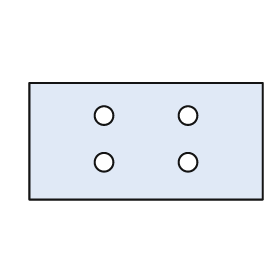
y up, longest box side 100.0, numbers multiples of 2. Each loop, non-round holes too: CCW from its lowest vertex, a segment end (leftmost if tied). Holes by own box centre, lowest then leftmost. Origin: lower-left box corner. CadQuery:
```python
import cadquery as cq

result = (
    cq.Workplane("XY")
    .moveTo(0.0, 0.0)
    .lineTo(100.0, 0.0)
    .lineTo(100.0, 50.0)
    .lineTo(0.0, 50.0)
    .close()
    .moveTo(32.0, 16.0)
    .circle(4.0)
    .moveTo(68.0, 16.0)
    .circle(4.0)
    .moveTo(32.0, 36.0)
    .circle(4.0)
    .moveTo(68.0, 36.0)
    .circle(4.0)
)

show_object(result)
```